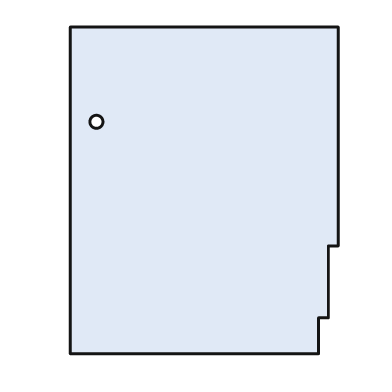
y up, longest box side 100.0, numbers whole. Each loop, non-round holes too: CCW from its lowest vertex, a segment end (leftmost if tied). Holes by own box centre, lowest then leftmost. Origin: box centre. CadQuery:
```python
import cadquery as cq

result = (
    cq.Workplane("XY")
    .moveTo(-41.0, -50.0)
    .lineTo(35.0, -50.0)
    .lineTo(35.0, -39.0)
    .lineTo(38.0, -39.0)
    .lineTo(38.0, -17.0)
    .lineTo(41.0, -17.0)
    .lineTo(41.0, 50.0)
    .lineTo(-41.0, 50.0)
    .close()
    .moveTo(-33.0, 21.0)
    .circle(2.0)
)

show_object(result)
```